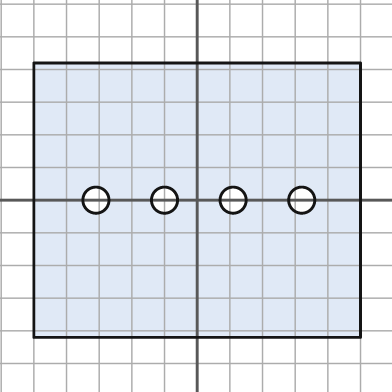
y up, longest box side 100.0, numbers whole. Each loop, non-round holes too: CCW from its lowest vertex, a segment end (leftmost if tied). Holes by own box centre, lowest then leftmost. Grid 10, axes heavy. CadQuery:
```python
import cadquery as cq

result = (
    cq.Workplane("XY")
    .moveTo(-50.0, -42.0)
    .lineTo(50.0, -42.0)
    .lineTo(50.0, 42.0)
    .lineTo(-50.0, 42.0)
    .close()
    .moveTo(-31.0, 0.0)
    .circle(4.0)
    .moveTo(-10.0, 0.0)
    .circle(4.0)
    .moveTo(11.0, 0.0)
    .circle(4.0)
    .moveTo(32.0, 0.0)
    .circle(4.0)
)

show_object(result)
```